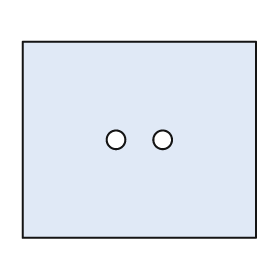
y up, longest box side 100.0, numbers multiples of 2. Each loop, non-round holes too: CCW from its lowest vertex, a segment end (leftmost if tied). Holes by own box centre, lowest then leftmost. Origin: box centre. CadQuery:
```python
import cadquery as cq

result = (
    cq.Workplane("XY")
    .moveTo(-50.0, -42.0)
    .lineTo(50.0, -42.0)
    .lineTo(50.0, 42.0)
    .lineTo(-50.0, 42.0)
    .close()
    .moveTo(-10.0, 0.0)
    .circle(4.0)
    .moveTo(10.0, 0.0)
    .circle(4.0)
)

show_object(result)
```